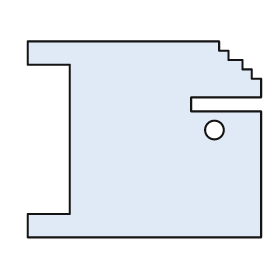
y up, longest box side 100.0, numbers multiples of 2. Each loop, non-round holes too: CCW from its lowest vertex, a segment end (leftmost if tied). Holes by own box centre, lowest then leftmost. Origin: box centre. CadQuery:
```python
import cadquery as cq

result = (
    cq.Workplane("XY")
    .moveTo(-50.0, -42.0)
    .lineTo(50.0, -42.0)
    .lineTo(50.0, 12.0)
    .lineTo(20.0, 12.0)
    .lineTo(20.0, 18.0)
    .lineTo(50.0, 18.0)
    .lineTo(50.0, 26.0)
    .lineTo(46.0, 26.0)
    .lineTo(46.0, 30.0)
    .lineTo(42.0, 30.0)
    .lineTo(42.0, 34.0)
    .lineTo(36.0, 34.0)
    .lineTo(36.0, 38.0)
    .lineTo(32.0, 38.0)
    .lineTo(32.0, 42.0)
    .lineTo(-50.0, 42.0)
    .lineTo(-50.0, 32.0)
    .lineTo(-32.0, 32.0)
    .lineTo(-32.0, -32.0)
    .lineTo(-50.0, -32.0)
    .close()
    .moveTo(30.0, 4.0)
    .circle(4.0)
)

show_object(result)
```